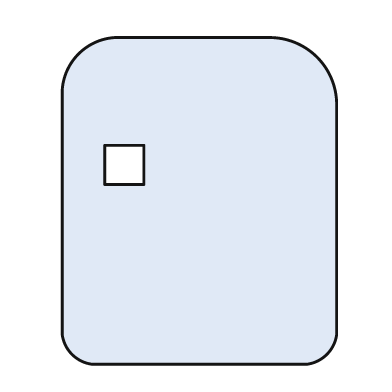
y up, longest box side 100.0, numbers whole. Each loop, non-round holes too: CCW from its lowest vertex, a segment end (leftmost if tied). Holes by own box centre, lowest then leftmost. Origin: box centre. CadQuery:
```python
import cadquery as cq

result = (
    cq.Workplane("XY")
    .moveTo(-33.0, -50.0)
    .lineTo(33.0, -50.0)
    .threePointArc((39.0, -47.0), (42.0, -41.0))
    .lineTo(42.0, 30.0)
    .threePointArc((36.0, 44.0), (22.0, 50.0))
    .lineTo(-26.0, 50.0)
    .threePointArc((-37.0, 45.0), (-42.0, 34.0))
    .lineTo(-42.0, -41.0)
    .threePointArc((-39.0, -47.0), (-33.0, -50.0))
    .close()
    .moveTo(-29.0, 5.0)
    .lineTo(-17.0, 5.0)
    .lineTo(-17.0, 17.0)
    .lineTo(-29.0, 17.0)
    .close()
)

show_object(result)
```